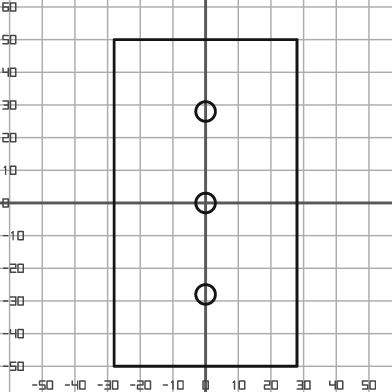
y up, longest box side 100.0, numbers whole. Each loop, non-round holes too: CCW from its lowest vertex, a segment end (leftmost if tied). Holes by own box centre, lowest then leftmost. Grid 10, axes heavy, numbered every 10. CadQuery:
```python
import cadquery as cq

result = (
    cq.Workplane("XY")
    .moveTo(-28.0, -50.0)
    .lineTo(28.0, -50.0)
    .lineTo(28.0, 50.0)
    .lineTo(-28.0, 50.0)
    .close()
    .moveTo(0.0, -28.0)
    .circle(3.0)
    .moveTo(0.0, 0.0)
    .circle(3.0)
    .moveTo(0.0, 28.0)
    .circle(3.0)
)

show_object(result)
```